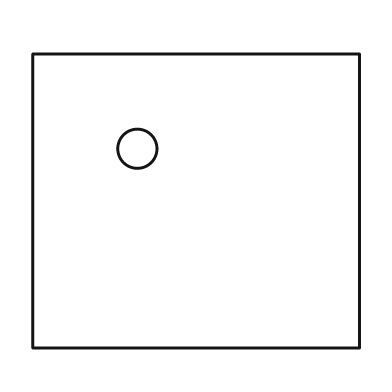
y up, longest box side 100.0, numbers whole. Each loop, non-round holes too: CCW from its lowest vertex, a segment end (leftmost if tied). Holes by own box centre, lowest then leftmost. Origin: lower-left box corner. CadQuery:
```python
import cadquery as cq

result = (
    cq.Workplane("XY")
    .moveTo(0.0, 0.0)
    .lineTo(100.0, 0.0)
    .lineTo(100.0, 90.0)
    .lineTo(0.0, 90.0)
    .close()
    .moveTo(32.0, 61.0)
    .circle(6.0)
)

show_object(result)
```